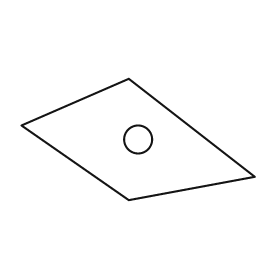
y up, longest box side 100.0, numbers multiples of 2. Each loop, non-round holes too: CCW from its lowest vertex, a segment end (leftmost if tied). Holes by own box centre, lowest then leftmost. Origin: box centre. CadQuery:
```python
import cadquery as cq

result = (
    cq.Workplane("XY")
    .moveTo(-4.0, -26.0)
    .lineTo(50.0, -16.0)
    .lineTo(-4.0, 26.0)
    .lineTo(-50.0, 6.0)
    .close()
    .moveTo(0.0, 0.0)
    .circle(6.0)
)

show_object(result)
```